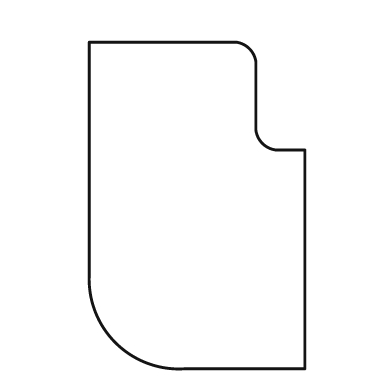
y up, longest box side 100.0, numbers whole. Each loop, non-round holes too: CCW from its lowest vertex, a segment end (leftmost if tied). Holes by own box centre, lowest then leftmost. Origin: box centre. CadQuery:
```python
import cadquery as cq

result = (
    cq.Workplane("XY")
    .moveTo(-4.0, -50.0)
    .lineTo(33.0, -50.0)
    .lineTo(33.0, 17.0)
    .lineTo(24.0, 17.0)
    .threePointArc((20.0, 19.0), (18.0, 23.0))
    .lineTo(18.0, 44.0)
    .threePointArc((16.0, 48.0), (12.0, 50.0))
    .lineTo(-33.0, 50.0)
    .lineTo(-33.0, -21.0)
    .threePointArc((-25.0, -42.0), (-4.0, -50.0))
    .close()
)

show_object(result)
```